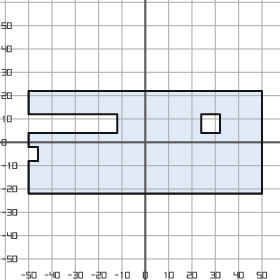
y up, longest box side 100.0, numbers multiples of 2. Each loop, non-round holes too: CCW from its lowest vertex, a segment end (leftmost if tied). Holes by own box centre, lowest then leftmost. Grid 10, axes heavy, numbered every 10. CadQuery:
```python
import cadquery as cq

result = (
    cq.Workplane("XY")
    .moveTo(-50.0, -22.0)
    .lineTo(50.0, -22.0)
    .lineTo(50.0, 22.0)
    .lineTo(-50.0, 22.0)
    .lineTo(-50.0, 12.0)
    .lineTo(-12.0, 12.0)
    .lineTo(-12.0, 4.0)
    .lineTo(-50.0, 4.0)
    .lineTo(-50.0, -2.0)
    .lineTo(-46.0, -2.0)
    .lineTo(-46.0, -8.0)
    .lineTo(-50.0, -8.0)
    .close()
    .moveTo(24.0, 4.0)
    .lineTo(32.0, 4.0)
    .lineTo(32.0, 12.0)
    .lineTo(24.0, 12.0)
    .close()
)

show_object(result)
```